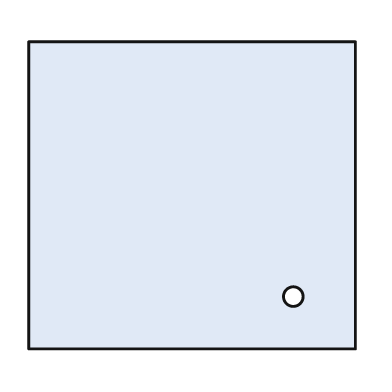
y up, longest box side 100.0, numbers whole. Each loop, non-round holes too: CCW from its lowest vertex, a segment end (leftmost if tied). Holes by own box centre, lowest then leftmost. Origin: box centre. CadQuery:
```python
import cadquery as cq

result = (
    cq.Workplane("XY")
    .moveTo(-50.0, -47.0)
    .lineTo(50.0, -47.0)
    .lineTo(50.0, 47.0)
    .lineTo(-50.0, 47.0)
    .close()
    .moveTo(31.0, -31.0)
    .circle(3.0)
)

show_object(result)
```